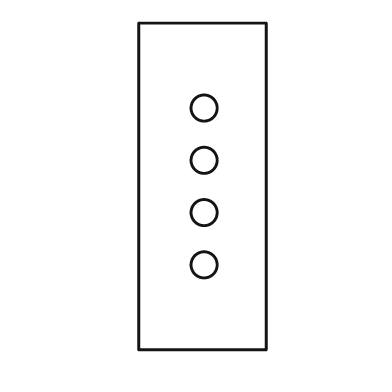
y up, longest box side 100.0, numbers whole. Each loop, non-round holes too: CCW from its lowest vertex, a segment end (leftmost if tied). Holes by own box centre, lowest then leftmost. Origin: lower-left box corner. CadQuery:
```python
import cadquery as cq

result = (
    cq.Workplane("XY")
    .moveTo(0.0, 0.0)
    .lineTo(39.0, 0.0)
    .lineTo(39.0, 100.0)
    .lineTo(0.0, 100.0)
    .close()
    .moveTo(20.0, 26.0)
    .circle(4.0)
    .moveTo(20.0, 42.0)
    .circle(4.0)
    .moveTo(20.0, 58.0)
    .circle(4.0)
    .moveTo(20.0, 74.0)
    .circle(4.0)
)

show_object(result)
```